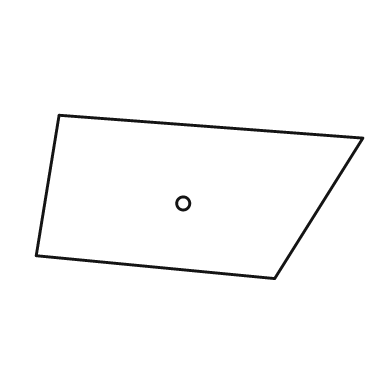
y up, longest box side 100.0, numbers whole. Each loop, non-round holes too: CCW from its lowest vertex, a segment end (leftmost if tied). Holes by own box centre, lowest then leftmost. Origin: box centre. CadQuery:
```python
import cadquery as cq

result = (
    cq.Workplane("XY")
    .moveTo(23.0, -25.0)
    .lineTo(50.0, 18.0)
    .lineTo(-43.0, 25.0)
    .lineTo(-50.0, -18.0)
    .close()
    .moveTo(-5.0, -2.0)
    .circle(2.0)
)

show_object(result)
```